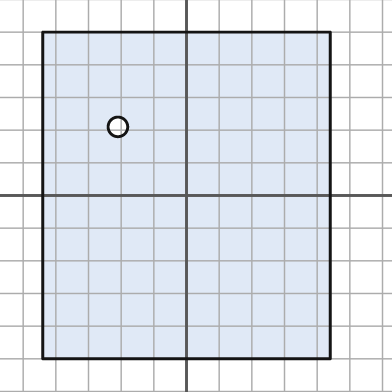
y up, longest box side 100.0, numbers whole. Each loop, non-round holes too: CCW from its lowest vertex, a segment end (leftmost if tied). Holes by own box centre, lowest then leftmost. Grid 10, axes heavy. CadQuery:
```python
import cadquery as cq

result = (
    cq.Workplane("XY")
    .moveTo(-44.0, -50.0)
    .lineTo(44.0, -50.0)
    .lineTo(44.0, 50.0)
    .lineTo(-44.0, 50.0)
    .close()
    .moveTo(-21.0, 21.0)
    .circle(3.0)
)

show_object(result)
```